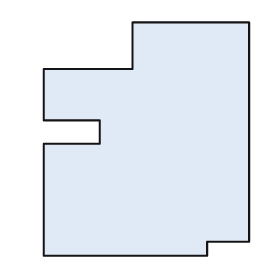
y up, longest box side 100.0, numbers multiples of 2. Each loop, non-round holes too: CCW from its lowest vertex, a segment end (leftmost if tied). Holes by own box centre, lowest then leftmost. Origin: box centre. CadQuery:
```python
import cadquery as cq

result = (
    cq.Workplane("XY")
    .moveTo(-44.0, -50.0)
    .lineTo(26.0, -50.0)
    .lineTo(26.0, -44.0)
    .lineTo(44.0, -44.0)
    .lineTo(44.0, 50.0)
    .lineTo(-6.0, 50.0)
    .lineTo(-6.0, 30.0)
    .lineTo(-44.0, 30.0)
    .lineTo(-44.0, 8.0)
    .lineTo(-20.0, 8.0)
    .lineTo(-20.0, -2.0)
    .lineTo(-44.0, -2.0)
    .close()
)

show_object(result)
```